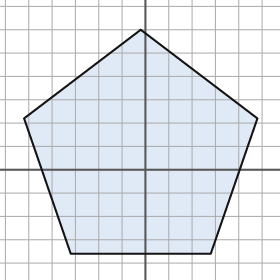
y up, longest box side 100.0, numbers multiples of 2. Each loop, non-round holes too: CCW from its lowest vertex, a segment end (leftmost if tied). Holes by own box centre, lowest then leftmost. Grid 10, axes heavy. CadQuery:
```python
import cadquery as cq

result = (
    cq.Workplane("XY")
    .moveTo(-32.0, -36.0)
    .lineTo(28.0, -36.0)
    .lineTo(48.0, 22.0)
    .lineTo(-2.0, 60.0)
    .lineTo(-52.0, 22.0)
    .close()
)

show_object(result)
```